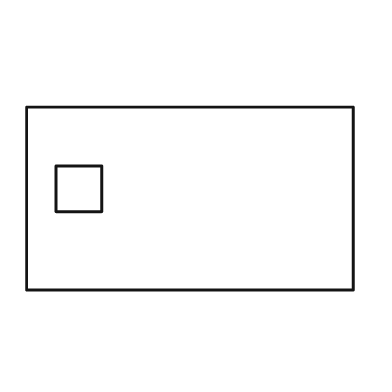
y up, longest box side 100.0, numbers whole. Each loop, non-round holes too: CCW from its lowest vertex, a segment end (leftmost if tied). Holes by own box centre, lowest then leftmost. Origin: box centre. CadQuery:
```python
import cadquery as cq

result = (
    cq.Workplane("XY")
    .moveTo(-50.0, -28.0)
    .lineTo(50.0, -28.0)
    .lineTo(50.0, 28.0)
    .lineTo(-50.0, 28.0)
    .close()
    .moveTo(-41.0, -4.0)
    .lineTo(-27.0, -4.0)
    .lineTo(-27.0, 10.0)
    .lineTo(-41.0, 10.0)
    .close()
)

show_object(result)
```